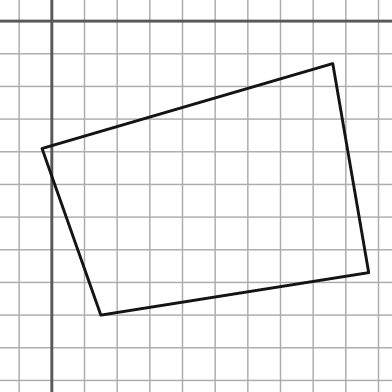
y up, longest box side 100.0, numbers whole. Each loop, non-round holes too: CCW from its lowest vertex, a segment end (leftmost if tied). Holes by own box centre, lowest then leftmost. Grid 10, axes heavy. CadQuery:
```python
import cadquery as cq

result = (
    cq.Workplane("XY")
    .moveTo(15.0, -90.0)
    .lineTo(97.0, -77.0)
    .lineTo(86.0, -13.0)
    .lineTo(-3.0, -39.0)
    .close()
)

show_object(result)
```